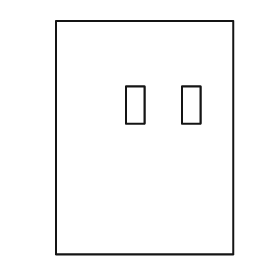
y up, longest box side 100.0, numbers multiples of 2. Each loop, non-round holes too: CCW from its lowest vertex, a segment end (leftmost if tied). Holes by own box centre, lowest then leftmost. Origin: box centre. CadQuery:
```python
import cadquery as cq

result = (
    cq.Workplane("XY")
    .moveTo(-38.0, -50.0)
    .lineTo(38.0, -50.0)
    .lineTo(38.0, 50.0)
    .lineTo(-38.0, 50.0)
    .close()
    .moveTo(-8.0, 6.0)
    .lineTo(0.0, 6.0)
    .lineTo(0.0, 22.0)
    .lineTo(-8.0, 22.0)
    .close()
    .moveTo(16.0, 6.0)
    .lineTo(24.0, 6.0)
    .lineTo(24.0, 22.0)
    .lineTo(16.0, 22.0)
    .close()
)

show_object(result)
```